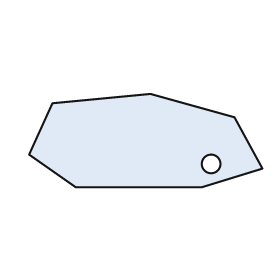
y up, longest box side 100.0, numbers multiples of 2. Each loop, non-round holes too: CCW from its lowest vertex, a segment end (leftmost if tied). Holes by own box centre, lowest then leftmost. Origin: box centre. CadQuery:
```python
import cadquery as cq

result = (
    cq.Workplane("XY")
    .moveTo(-30.0, -20.0)
    .lineTo(24.0, -20.0)
    .lineTo(50.0, -12.0)
    .lineTo(38.0, 10.0)
    .lineTo(2.0, 20.0)
    .lineTo(-40.0, 16.0)
    .lineTo(-50.0, -6.0)
    .close()
    .moveTo(28.0, -10.0)
    .circle(4.0)
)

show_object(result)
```